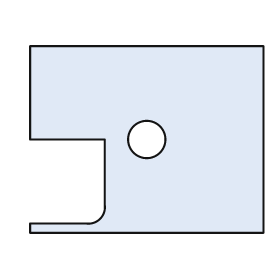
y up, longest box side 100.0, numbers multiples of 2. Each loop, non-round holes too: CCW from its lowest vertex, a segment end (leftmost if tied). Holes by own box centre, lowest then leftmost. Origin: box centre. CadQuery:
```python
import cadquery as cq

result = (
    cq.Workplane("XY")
    .moveTo(-50.0, -40.0)
    .lineTo(50.0, -40.0)
    .lineTo(50.0, 40.0)
    .lineTo(-50.0, 40.0)
    .lineTo(-50.0, 0.0)
    .lineTo(-18.0, 0.0)
    .lineTo(-18.0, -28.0)
    .threePointArc((-20.0, -34.0), (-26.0, -36.0))
    .lineTo(-50.0, -36.0)
    .close()
    .moveTo(0.0, 0.0)
    .circle(8.0)
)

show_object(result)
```